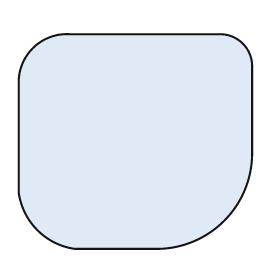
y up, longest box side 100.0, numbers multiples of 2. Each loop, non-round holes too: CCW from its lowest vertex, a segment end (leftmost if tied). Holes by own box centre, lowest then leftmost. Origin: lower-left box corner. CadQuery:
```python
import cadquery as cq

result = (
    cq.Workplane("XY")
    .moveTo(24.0, 0.0)
    .lineTo(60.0, 0.0)
    .threePointArc((88.0, 12.0), (100.0, 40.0))
    .lineTo(100.0, 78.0)
    .threePointArc((96.0, 88.0), (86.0, 92.0))
    .lineTo(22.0, 92.0)
    .threePointArc((6.0, 86.0), (0.0, 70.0))
    .lineTo(0.0, 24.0)
    .threePointArc((8.0, 8.0), (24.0, 0.0))
    .close()
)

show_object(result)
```